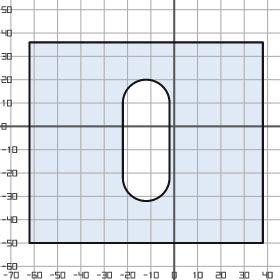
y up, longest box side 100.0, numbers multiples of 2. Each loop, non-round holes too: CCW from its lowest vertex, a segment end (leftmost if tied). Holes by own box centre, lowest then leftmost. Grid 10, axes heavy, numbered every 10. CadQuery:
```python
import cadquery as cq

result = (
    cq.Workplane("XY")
    .moveTo(-62.0, -50.0)
    .lineTo(38.0, -50.0)
    .lineTo(38.0, 36.0)
    .lineTo(-62.0, 36.0)
    .close()
    .moveTo(-22.0, -22.0)
    .threePointArc((-12.0, -32.0), (-2.0, -22.0))
    .lineTo(-2.0, 10.0)
    .threePointArc((-12.0, 20.0), (-22.0, 10.0))
    .close()
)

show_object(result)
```